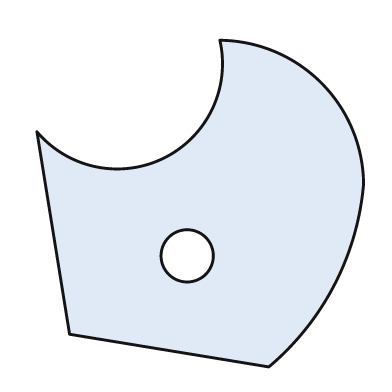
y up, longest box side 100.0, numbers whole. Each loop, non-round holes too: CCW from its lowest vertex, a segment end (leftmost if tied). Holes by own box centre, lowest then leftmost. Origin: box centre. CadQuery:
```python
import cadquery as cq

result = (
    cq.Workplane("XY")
    .moveTo(21.0, -50.0)
    .threePointArc((41.0, -25.0), (50.0, 6.0))
    .threePointArc((37.0, 37.0), (6.0, 50.0))
    .threePointArc((-11.0, 14.0), (-50.0, 22.0))
    .lineTo(-40.0, -40.0)
    .close()
    .moveTo(-4.0, -16.0)
    .circle(8.0)
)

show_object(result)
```